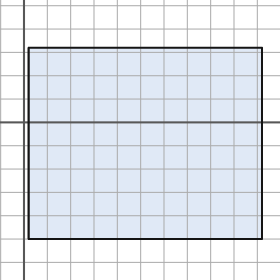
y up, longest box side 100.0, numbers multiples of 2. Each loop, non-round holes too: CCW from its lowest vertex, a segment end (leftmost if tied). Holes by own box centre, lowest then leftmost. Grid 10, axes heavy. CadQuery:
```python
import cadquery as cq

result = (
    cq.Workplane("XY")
    .moveTo(2.0, -50.0)
    .lineTo(102.0, -50.0)
    .lineTo(102.0, 32.0)
    .lineTo(2.0, 32.0)
    .close()
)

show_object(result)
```